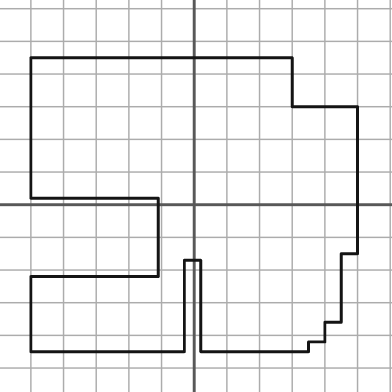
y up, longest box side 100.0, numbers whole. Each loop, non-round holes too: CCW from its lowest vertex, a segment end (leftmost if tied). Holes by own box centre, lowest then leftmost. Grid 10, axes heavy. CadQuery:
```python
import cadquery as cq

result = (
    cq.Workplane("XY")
    .moveTo(-50.0, -45.0)
    .lineTo(-3.0, -45.0)
    .lineTo(-3.0, -17.0)
    .lineTo(2.0, -17.0)
    .lineTo(2.0, -45.0)
    .lineTo(35.0, -45.0)
    .lineTo(35.0, -42.0)
    .lineTo(40.0, -42.0)
    .lineTo(40.0, -36.0)
    .lineTo(45.0, -36.0)
    .lineTo(45.0, -15.0)
    .lineTo(50.0, -15.0)
    .lineTo(50.0, 30.0)
    .lineTo(30.0, 30.0)
    .lineTo(30.0, 45.0)
    .lineTo(-50.0, 45.0)
    .lineTo(-50.0, 2.0)
    .lineTo(-11.0, 2.0)
    .lineTo(-11.0, -22.0)
    .lineTo(-50.0, -22.0)
    .close()
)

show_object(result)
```